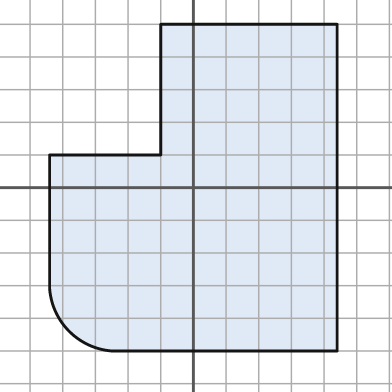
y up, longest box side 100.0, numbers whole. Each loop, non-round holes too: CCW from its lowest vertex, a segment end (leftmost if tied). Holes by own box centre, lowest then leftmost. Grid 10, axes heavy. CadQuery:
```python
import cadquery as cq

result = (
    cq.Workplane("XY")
    .moveTo(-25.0, -50.0)
    .lineTo(44.0, -50.0)
    .lineTo(44.0, 50.0)
    .lineTo(-10.0, 50.0)
    .lineTo(-10.0, 10.0)
    .lineTo(-44.0, 10.0)
    .lineTo(-44.0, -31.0)
    .threePointArc((-38.0, -44.0), (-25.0, -50.0))
    .close()
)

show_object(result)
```